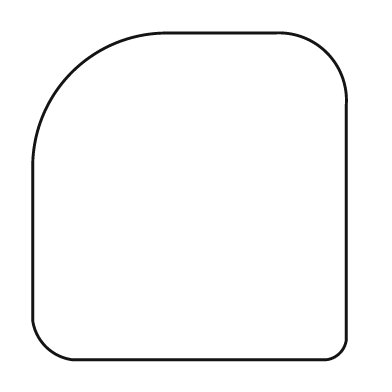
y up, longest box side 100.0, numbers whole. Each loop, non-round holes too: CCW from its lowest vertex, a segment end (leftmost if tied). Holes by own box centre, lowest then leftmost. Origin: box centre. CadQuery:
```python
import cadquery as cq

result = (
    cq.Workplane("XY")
    .moveTo(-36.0, -50.0)
    .lineTo(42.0, -50.0)
    .threePointArc((46.0, -48.0), (48.0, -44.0))
    .lineTo(48.0, 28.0)
    .threePointArc((42.0, 44.0), (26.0, 50.0))
    .lineTo(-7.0, 50.0)
    .threePointArc((-36.0, 38.0), (-48.0, 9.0))
    .lineTo(-48.0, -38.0)
    .threePointArc((-44.0, -46.0), (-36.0, -50.0))
    .close()
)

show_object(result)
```